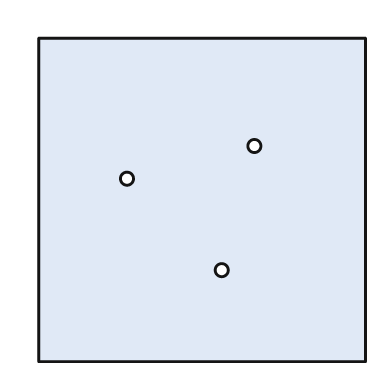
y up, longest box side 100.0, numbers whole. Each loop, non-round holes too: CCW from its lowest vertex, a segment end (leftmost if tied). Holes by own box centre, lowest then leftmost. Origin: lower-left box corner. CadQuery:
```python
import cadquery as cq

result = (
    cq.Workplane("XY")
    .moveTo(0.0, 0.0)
    .lineTo(100.0, 0.0)
    .lineTo(100.0, 99.0)
    .lineTo(0.0, 99.0)
    .close()
    .moveTo(56.0, 28.0)
    .circle(2.0)
    .moveTo(27.0, 56.0)
    .circle(2.0)
    .moveTo(66.0, 66.0)
    .circle(2.0)
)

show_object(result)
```